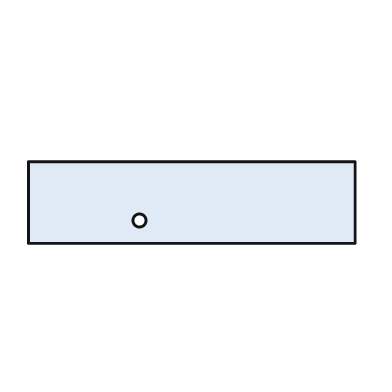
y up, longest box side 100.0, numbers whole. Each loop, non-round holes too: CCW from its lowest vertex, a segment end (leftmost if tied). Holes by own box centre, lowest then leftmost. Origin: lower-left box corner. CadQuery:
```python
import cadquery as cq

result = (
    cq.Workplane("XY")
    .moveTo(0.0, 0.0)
    .lineTo(100.0, 0.0)
    .lineTo(100.0, 25.0)
    .lineTo(0.0, 25.0)
    .close()
    .moveTo(34.0, 7.0)
    .circle(2.0)
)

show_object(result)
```